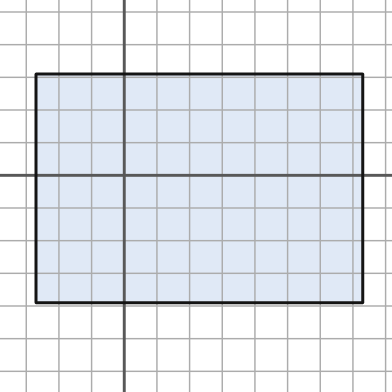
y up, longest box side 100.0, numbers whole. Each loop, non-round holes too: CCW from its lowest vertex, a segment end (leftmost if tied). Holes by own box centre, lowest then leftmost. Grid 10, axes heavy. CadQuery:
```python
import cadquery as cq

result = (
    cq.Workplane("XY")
    .moveTo(-27.0, -39.0)
    .lineTo(73.0, -39.0)
    .lineTo(73.0, 31.0)
    .lineTo(-27.0, 31.0)
    .close()
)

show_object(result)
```